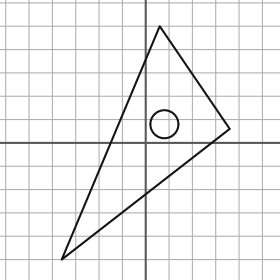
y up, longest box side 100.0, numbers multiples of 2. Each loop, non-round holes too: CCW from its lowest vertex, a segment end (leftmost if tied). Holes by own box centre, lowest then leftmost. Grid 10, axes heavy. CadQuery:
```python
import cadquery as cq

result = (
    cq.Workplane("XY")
    .moveTo(-36.0, -50.0)
    .lineTo(36.0, 6.0)
    .lineTo(6.0, 50.0)
    .close()
    .moveTo(8.0, 8.0)
    .circle(6.0)
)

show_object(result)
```